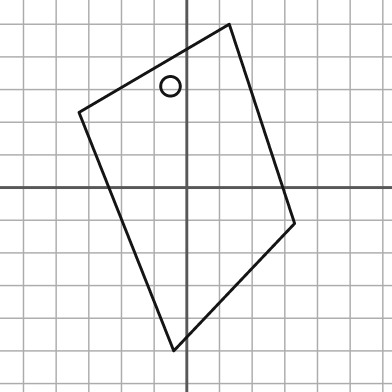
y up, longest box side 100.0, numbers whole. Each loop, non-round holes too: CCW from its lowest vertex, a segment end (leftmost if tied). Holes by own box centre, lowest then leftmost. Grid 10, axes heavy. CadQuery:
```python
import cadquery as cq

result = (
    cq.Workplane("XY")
    .moveTo(-4.0, -50.0)
    .lineTo(33.0, -11.0)
    .lineTo(13.0, 50.0)
    .lineTo(-33.0, 23.0)
    .close()
    .moveTo(-5.0, 31.0)
    .circle(3.0)
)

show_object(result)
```